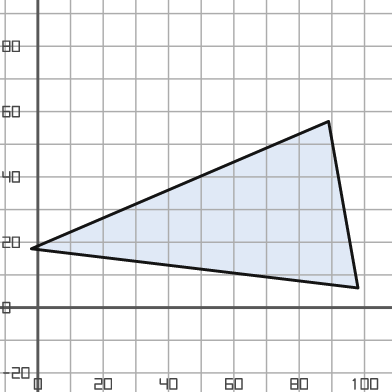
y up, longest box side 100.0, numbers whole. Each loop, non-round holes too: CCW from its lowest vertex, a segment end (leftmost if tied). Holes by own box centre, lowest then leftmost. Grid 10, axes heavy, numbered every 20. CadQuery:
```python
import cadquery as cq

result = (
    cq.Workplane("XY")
    .moveTo(98.0, 6.0)
    .lineTo(89.0, 57.0)
    .lineTo(-2.0, 18.0)
    .close()
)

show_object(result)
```